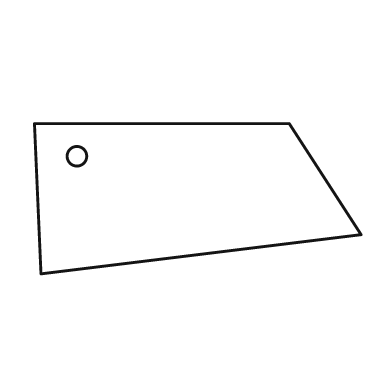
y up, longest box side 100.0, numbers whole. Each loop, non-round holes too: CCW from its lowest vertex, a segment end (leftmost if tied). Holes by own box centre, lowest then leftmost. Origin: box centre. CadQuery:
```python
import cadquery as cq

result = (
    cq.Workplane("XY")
    .moveTo(-48.0, -23.0)
    .lineTo(50.0, -11.0)
    .lineTo(28.0, 23.0)
    .lineTo(-50.0, 23.0)
    .close()
    .moveTo(-37.0, 13.0)
    .circle(3.0)
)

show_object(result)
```